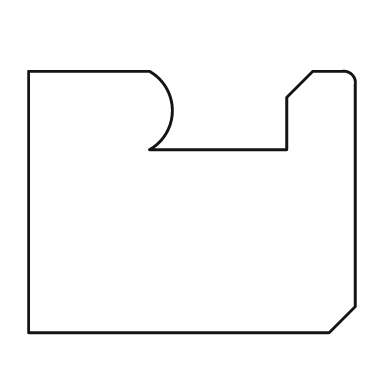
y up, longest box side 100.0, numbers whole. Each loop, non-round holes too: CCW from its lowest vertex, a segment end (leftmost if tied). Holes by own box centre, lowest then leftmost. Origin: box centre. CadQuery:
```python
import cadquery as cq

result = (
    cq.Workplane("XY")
    .moveTo(-50.0, -40.0)
    .lineTo(42.0, -40.0)
    .lineTo(50.0, -32.0)
    .lineTo(50.0, 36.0)
    .threePointArc((49.0, 39.0), (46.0, 40.0))
    .lineTo(37.0, 40.0)
    .lineTo(29.0, 32.0)
    .lineTo(29.0, 16.0)
    .lineTo(-13.0, 16.0)
    .threePointArc((-6.0, 28.0), (-13.0, 40.0))
    .lineTo(-50.0, 40.0)
    .close()
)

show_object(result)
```